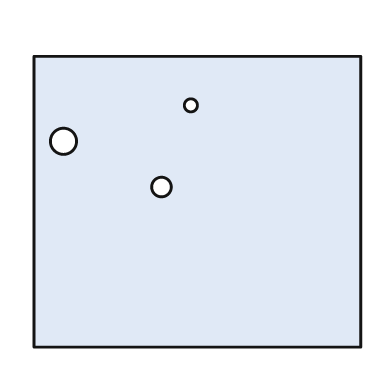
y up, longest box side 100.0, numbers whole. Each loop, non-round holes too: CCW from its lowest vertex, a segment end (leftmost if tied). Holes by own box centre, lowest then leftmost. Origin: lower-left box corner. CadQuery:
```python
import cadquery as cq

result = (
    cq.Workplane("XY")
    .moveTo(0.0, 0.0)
    .lineTo(100.0, 0.0)
    .lineTo(100.0, 89.0)
    .lineTo(0.0, 89.0)
    .close()
    .moveTo(39.0, 49.0)
    .circle(3.0)
    .moveTo(9.0, 63.0)
    .circle(4.0)
    .moveTo(48.0, 74.0)
    .circle(2.0)
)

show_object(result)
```